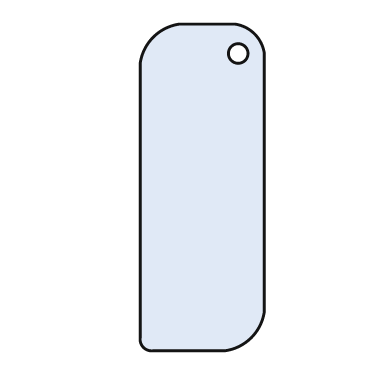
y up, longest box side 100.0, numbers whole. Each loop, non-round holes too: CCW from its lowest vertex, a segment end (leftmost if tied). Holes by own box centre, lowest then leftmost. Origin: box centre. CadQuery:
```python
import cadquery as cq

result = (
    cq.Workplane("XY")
    .moveTo(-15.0, -50.0)
    .lineTo(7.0, -50.0)
    .threePointArc((15.0, -46.0), (19.0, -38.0))
    .lineTo(19.0, 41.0)
    .threePointArc((16.0, 47.0), (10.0, 50.0))
    .lineTo(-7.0, 50.0)
    .threePointArc((-15.0, 46.0), (-19.0, 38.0))
    .lineTo(-19.0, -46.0)
    .threePointArc((-18.0, -49.0), (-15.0, -50.0))
    .close()
    .moveTo(11.0, 41.0)
    .circle(3.0)
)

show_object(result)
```